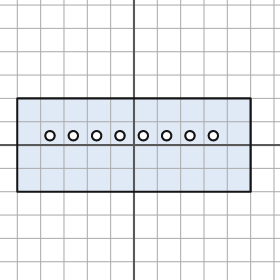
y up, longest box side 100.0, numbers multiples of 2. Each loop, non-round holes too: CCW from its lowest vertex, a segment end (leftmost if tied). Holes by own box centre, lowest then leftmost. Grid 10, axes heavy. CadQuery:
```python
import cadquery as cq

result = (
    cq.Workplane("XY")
    .moveTo(-50.0, -20.0)
    .lineTo(50.0, -20.0)
    .lineTo(50.0, 20.0)
    .lineTo(-50.0, 20.0)
    .close()
    .moveTo(-36.0, 4.0)
    .circle(2.0)
    .moveTo(-26.0, 4.0)
    .circle(2.0)
    .moveTo(-16.0, 4.0)
    .circle(2.0)
    .moveTo(-6.0, 4.0)
    .circle(2.0)
    .moveTo(4.0, 4.0)
    .circle(2.0)
    .moveTo(14.0, 4.0)
    .circle(2.0)
    .moveTo(24.0, 4.0)
    .circle(2.0)
    .moveTo(34.0, 4.0)
    .circle(2.0)
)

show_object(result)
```